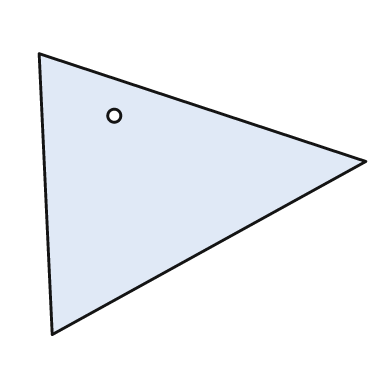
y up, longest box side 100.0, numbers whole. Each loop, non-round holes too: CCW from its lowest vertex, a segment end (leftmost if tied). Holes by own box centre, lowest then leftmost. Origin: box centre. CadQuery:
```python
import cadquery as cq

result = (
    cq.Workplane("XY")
    .moveTo(-46.0, -43.0)
    .lineTo(50.0, 10.0)
    .lineTo(-50.0, 43.0)
    .close()
    .moveTo(-27.0, 24.0)
    .circle(2.0)
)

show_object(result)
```